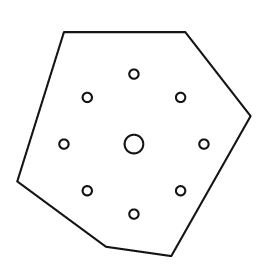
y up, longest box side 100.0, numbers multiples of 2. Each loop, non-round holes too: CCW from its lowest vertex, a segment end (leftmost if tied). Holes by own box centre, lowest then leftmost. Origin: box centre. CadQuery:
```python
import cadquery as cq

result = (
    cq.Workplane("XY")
    .moveTo(16.0, -48.0)
    .lineTo(50.0, 12.0)
    .lineTo(22.0, 48.0)
    .lineTo(-30.0, 48.0)
    .lineTo(-50.0, -16.0)
    .lineTo(-12.0, -44.0)
    .close()
    .moveTo(0.0, -30.0)
    .circle(2.0)
    .moveTo(-20.0, -20.0)
    .circle(2.0)
    .moveTo(20.0, -20.0)
    .circle(2.0)
    .moveTo(-30.0, 0.0)
    .circle(2.0)
    .moveTo(0.0, 0.0)
    .circle(4.0)
    .moveTo(30.0, 0.0)
    .circle(2.0)
    .moveTo(-20.0, 20.0)
    .circle(2.0)
    .moveTo(20.0, 20.0)
    .circle(2.0)
    .moveTo(0.0, 30.0)
    .circle(2.0)
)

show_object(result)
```